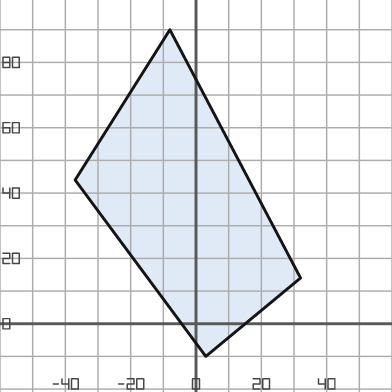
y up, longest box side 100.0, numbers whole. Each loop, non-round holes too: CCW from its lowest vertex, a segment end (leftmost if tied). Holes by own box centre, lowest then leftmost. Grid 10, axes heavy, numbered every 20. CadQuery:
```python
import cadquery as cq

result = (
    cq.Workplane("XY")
    .moveTo(3.0, -10.0)
    .lineTo(32.0, 14.0)
    .lineTo(-8.0, 90.0)
    .lineTo(-37.0, 44.0)
    .close()
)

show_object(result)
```